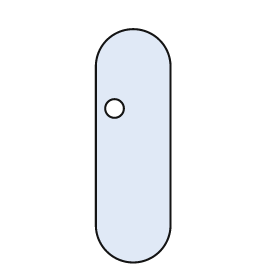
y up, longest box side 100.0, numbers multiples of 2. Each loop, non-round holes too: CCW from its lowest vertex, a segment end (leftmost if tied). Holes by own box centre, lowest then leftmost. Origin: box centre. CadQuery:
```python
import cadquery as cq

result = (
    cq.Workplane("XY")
    .moveTo(-16.0, -34.0)
    .threePointArc((0.0, -50.0), (16.0, -34.0))
    .lineTo(16.0, 34.0)
    .threePointArc((0.0, 50.0), (-16.0, 34.0))
    .close()
    .moveTo(-8.0, 16.0)
    .circle(4.0)
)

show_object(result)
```